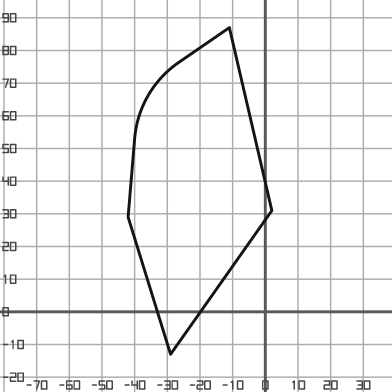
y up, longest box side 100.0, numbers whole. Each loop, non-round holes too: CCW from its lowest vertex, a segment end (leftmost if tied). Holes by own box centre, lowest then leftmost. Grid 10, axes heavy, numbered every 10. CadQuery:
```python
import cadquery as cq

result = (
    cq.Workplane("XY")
    .moveTo(-29.0, -13.0)
    .lineTo(2.0, 31.0)
    .lineTo(-11.0, 87.0)
    .lineTo(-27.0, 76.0)
    .threePointArc((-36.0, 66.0), (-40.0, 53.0))
    .lineTo(-42.0, 29.0)
    .close()
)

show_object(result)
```